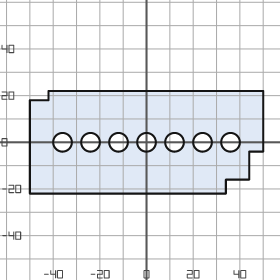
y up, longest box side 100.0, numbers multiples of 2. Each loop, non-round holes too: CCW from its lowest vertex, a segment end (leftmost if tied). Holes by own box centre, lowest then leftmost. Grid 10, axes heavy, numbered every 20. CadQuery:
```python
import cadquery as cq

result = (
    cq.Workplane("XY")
    .moveTo(-50.0, -22.0)
    .lineTo(34.0, -22.0)
    .lineTo(34.0, -16.0)
    .lineTo(44.0, -16.0)
    .lineTo(44.0, -4.0)
    .lineTo(50.0, -4.0)
    .lineTo(50.0, 22.0)
    .lineTo(-42.0, 22.0)
    .lineTo(-42.0, 18.0)
    .lineTo(-50.0, 18.0)
    .close()
    .moveTo(-36.0, 0.0)
    .circle(4.0)
    .moveTo(-24.0, 0.0)
    .circle(4.0)
    .moveTo(-12.0, 0.0)
    .circle(4.0)
    .moveTo(0.0, 0.0)
    .circle(4.0)
    .moveTo(12.0, 0.0)
    .circle(4.0)
    .moveTo(24.0, 0.0)
    .circle(4.0)
    .moveTo(36.0, 0.0)
    .circle(4.0)
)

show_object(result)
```